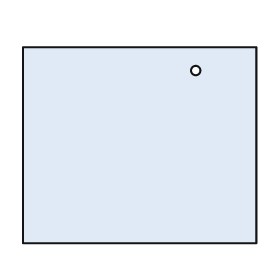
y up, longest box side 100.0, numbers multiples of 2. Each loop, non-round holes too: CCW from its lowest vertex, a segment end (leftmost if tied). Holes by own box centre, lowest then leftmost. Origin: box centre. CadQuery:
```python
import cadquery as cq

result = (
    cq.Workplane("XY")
    .moveTo(-50.0, -42.0)
    .lineTo(50.0, -42.0)
    .lineTo(50.0, 42.0)
    .lineTo(-50.0, 42.0)
    .close()
    .moveTo(24.0, 32.0)
    .circle(2.0)
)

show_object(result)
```